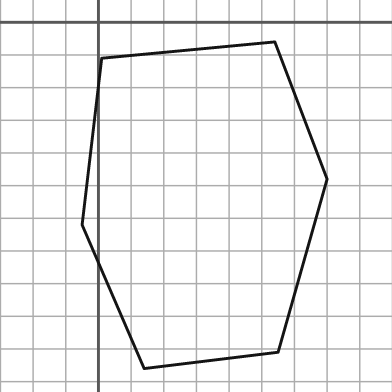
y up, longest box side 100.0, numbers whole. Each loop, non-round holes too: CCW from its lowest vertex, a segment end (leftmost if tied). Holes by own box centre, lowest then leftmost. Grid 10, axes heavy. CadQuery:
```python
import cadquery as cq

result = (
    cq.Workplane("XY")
    .moveTo(14.0, -106.0)
    .lineTo(55.0, -101.0)
    .lineTo(70.0, -48.0)
    .lineTo(54.0, -6.0)
    .lineTo(1.0, -11.0)
    .lineTo(-5.0, -62.0)
    .close()
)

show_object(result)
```